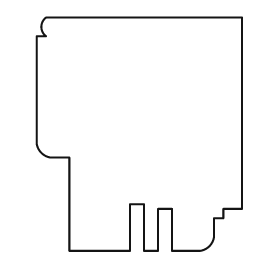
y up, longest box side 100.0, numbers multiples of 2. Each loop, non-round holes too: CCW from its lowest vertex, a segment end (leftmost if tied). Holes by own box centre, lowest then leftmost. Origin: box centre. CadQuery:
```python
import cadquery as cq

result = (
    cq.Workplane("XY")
    .moveTo(-30.0, -50.0)
    .lineTo(-4.0, -50.0)
    .lineTo(-4.0, -30.0)
    .lineTo(2.0, -30.0)
    .lineTo(2.0, -50.0)
    .lineTo(8.0, -50.0)
    .lineTo(8.0, -32.0)
    .lineTo(14.0, -32.0)
    .lineTo(14.0, -50.0)
    .lineTo(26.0, -50.0)
    .threePointArc((30.0, -48.0), (32.0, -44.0))
    .lineTo(32.0, -36.0)
    .lineTo(36.0, -36.0)
    .lineTo(36.0, -32.0)
    .lineTo(44.0, -32.0)
    .lineTo(44.0, 50.0)
    .lineTo(-40.0, 50.0)
    .threePointArc((-42.0, 46.0), (-40.0, 42.0))
    .lineTo(-44.0, 42.0)
    .lineTo(-44.0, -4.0)
    .threePointArc((-42.0, -8.0), (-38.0, -10.0))
    .lineTo(-30.0, -10.0)
    .close()
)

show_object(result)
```